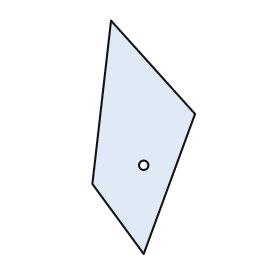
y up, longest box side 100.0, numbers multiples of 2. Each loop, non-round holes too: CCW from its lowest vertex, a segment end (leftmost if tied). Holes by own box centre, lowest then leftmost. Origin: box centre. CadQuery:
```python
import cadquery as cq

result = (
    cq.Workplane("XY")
    .moveTo(0.0, -50.0)
    .lineTo(22.0, 10.0)
    .lineTo(-14.0, 50.0)
    .lineTo(-22.0, -20.0)
    .close()
    .moveTo(0.0, -12.0)
    .circle(2.0)
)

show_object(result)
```